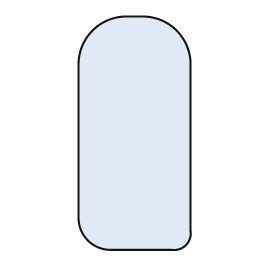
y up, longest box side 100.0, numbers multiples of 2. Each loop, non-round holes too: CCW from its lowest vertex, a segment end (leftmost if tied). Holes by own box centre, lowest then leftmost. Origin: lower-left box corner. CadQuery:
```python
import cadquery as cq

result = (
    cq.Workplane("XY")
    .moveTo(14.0, 0.0)
    .lineTo(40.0, 0.0)
    .threePointArc((46.0, 2.0), (48.0, 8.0))
    .lineTo(48.0, 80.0)
    .threePointArc((42.0, 94.0), (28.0, 100.0))
    .lineTo(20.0, 100.0)
    .threePointArc((6.0, 94.0), (0.0, 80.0))
    .lineTo(0.0, 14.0)
    .threePointArc((4.0, 4.0), (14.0, 0.0))
    .close()
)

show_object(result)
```